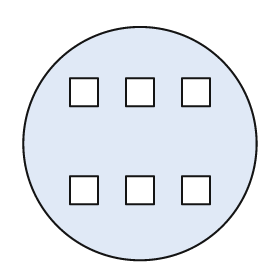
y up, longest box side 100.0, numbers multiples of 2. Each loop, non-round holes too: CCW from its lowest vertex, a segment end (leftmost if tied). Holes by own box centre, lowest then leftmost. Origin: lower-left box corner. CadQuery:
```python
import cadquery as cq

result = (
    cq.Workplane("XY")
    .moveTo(50.0, 50.0)
    .circle(50.0)
    .moveTo(20.0, 24.0)
    .lineTo(32.0, 24.0)
    .lineTo(32.0, 36.0)
    .lineTo(20.0, 36.0)
    .close()
    .moveTo(44.0, 24.0)
    .lineTo(56.0, 24.0)
    .lineTo(56.0, 36.0)
    .lineTo(44.0, 36.0)
    .close()
    .moveTo(68.0, 24.0)
    .lineTo(80.0, 24.0)
    .lineTo(80.0, 36.0)
    .lineTo(68.0, 36.0)
    .close()
    .moveTo(20.0, 66.0)
    .lineTo(32.0, 66.0)
    .lineTo(32.0, 78.0)
    .lineTo(20.0, 78.0)
    .close()
    .moveTo(44.0, 66.0)
    .lineTo(56.0, 66.0)
    .lineTo(56.0, 78.0)
    .lineTo(44.0, 78.0)
    .close()
    .moveTo(68.0, 66.0)
    .lineTo(80.0, 66.0)
    .lineTo(80.0, 78.0)
    .lineTo(68.0, 78.0)
    .close()
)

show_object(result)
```